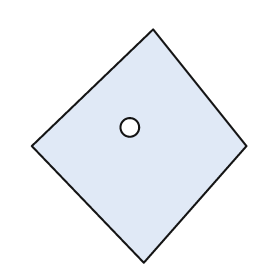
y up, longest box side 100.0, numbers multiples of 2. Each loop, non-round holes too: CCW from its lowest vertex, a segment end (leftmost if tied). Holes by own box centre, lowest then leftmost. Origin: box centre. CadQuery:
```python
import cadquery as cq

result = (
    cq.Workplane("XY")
    .moveTo(2.0, -50.0)
    .lineTo(46.0, 0.0)
    .lineTo(6.0, 50.0)
    .lineTo(-46.0, 0.0)
    .close()
    .moveTo(-4.0, 8.0)
    .circle(4.0)
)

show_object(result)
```